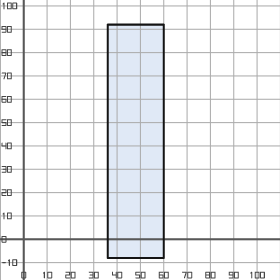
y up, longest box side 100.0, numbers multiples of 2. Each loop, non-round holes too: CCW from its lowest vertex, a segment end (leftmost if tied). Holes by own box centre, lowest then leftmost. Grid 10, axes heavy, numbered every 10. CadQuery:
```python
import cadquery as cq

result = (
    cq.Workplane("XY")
    .moveTo(36.0, -8.0)
    .lineTo(60.0, -8.0)
    .lineTo(60.0, 92.0)
    .lineTo(36.0, 92.0)
    .close()
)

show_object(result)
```